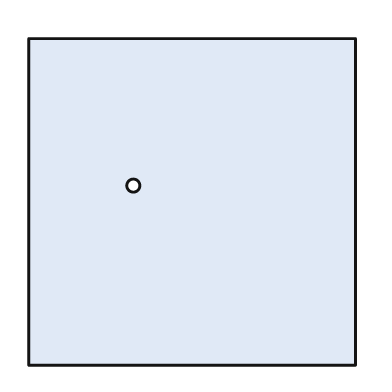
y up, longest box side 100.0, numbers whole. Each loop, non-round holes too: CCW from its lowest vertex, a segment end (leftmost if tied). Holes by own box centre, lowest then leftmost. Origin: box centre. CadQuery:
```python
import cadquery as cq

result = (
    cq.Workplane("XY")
    .moveTo(-50.0, -50.0)
    .lineTo(50.0, -50.0)
    .lineTo(50.0, 50.0)
    .lineTo(-50.0, 50.0)
    .close()
    .moveTo(-18.0, 5.0)
    .circle(2.0)
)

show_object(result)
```